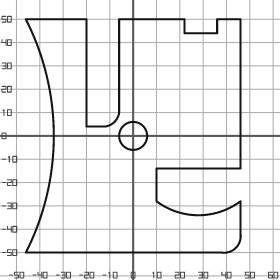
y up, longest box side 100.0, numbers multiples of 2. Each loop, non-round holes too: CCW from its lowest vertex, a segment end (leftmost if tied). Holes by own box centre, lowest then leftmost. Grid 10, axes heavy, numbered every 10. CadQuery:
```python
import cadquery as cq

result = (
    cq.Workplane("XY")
    .moveTo(-46.0, -50.0)
    .lineTo(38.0, -50.0)
    .threePointArc((44.0, -48.0), (46.0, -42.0))
    .lineTo(46.0, -28.0)
    .threePointArc((28.0, -34.0), (10.0, -28.0))
    .lineTo(10.0, -14.0)
    .lineTo(46.0, -14.0)
    .lineTo(46.0, 50.0)
    .lineTo(36.0, 50.0)
    .lineTo(36.0, 44.0)
    .lineTo(22.0, 44.0)
    .lineTo(22.0, 50.0)
    .lineTo(-6.0, 50.0)
    .lineTo(-6.0, 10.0)
    .threePointArc((-8.0, 6.0), (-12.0, 4.0))
    .lineTo(-20.0, 4.0)
    .lineTo(-20.0, 50.0)
    .lineTo(-46.0, 50.0)
    .threePointArc((-34.0, 0.0), (-46.0, -50.0))
    .close()
    .moveTo(0.0, 0.0)
    .circle(6.0)
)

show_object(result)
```